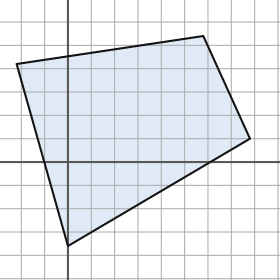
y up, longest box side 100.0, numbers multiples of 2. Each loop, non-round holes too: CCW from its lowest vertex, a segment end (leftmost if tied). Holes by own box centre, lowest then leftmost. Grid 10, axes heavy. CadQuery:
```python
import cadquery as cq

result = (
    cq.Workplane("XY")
    .moveTo(0.0, -36.0)
    .lineTo(78.0, 10.0)
    .lineTo(58.0, 54.0)
    .lineTo(-22.0, 42.0)
    .close()
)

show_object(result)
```